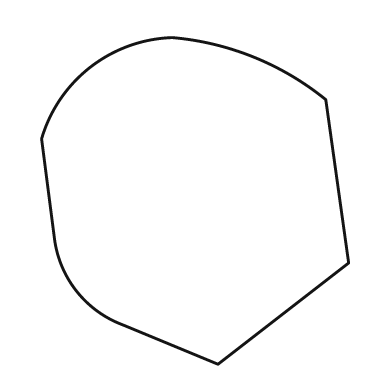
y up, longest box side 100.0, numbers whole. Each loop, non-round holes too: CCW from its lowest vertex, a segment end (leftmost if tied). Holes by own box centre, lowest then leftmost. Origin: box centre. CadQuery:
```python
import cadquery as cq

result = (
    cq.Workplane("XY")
    .moveTo(7.0, -50.0)
    .lineTo(47.0, -19.0)
    .lineTo(40.0, 31.0)
    .threePointArc((18.0, 44.0), (-7.0, 50.0))
    .threePointArc((-32.0, 41.0), (-47.0, 19.0))
    .lineTo(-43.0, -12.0)
    .threePointArc((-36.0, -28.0), (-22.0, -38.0))
    .close()
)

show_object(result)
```